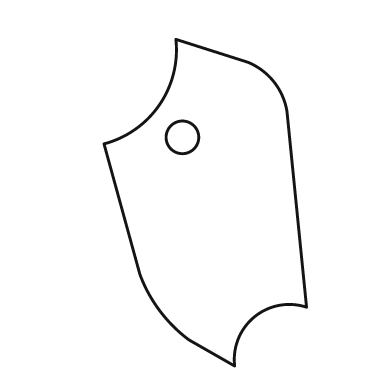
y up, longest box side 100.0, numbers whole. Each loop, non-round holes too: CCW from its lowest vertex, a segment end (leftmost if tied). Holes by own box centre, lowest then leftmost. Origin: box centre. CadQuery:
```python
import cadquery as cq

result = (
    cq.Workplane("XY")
    .moveTo(9.0, -50.0)
    .threePointArc((15.0, -35.0), (31.0, -32.0))
    .lineTo(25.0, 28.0)
    .threePointArc((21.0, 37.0), (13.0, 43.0))
    .lineTo(-9.0, 50.0)
    .threePointArc((-14.0, 30.0), (-31.0, 18.0))
    .lineTo(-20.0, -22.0)
    .threePointArc((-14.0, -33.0), (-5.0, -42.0))
    .close()
    .moveTo(-7.0, 20.0)
    .circle(5.0)
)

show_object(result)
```